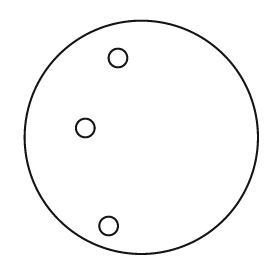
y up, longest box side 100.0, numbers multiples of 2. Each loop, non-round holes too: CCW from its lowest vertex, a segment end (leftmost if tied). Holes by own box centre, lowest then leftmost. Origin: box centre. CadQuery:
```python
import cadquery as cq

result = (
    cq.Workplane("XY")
    .moveTo(0.0, 0.0)
    .circle(50.0)
    .moveTo(-14.0, -38.0)
    .circle(4.0)
    .moveTo(-24.0, 4.0)
    .circle(4.0)
    .moveTo(-10.0, 34.0)
    .circle(4.0)
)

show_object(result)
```